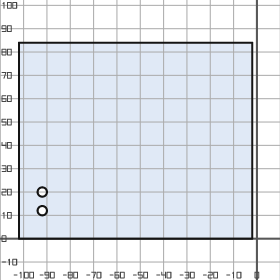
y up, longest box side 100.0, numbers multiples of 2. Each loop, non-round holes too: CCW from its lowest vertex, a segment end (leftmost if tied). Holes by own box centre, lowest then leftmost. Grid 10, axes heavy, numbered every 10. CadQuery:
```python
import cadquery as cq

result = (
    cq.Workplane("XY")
    .moveTo(-102.0, 0.0)
    .lineTo(-2.0, 0.0)
    .lineTo(-2.0, 84.0)
    .lineTo(-102.0, 84.0)
    .close()
    .moveTo(-92.0, 12.0)
    .circle(2.0)
    .moveTo(-92.0, 20.0)
    .circle(2.0)
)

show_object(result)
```